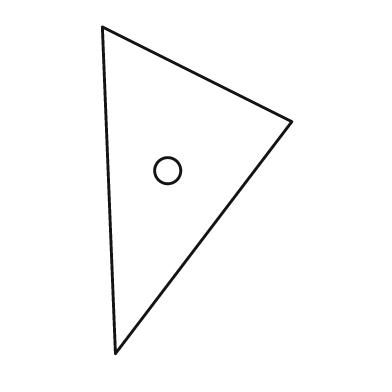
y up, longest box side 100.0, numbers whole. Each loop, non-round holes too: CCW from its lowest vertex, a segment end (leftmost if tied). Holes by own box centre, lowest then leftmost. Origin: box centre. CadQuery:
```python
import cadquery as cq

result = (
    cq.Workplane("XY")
    .moveTo(-25.0, -50.0)
    .lineTo(29.0, 21.0)
    .lineTo(-29.0, 50.0)
    .close()
    .moveTo(-9.0, 6.0)
    .circle(4.0)
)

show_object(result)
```